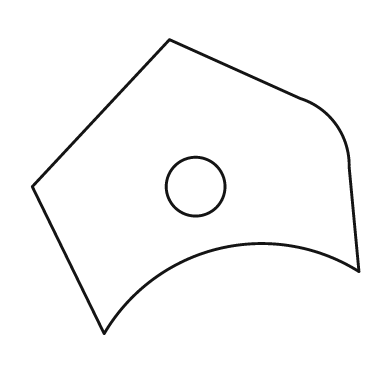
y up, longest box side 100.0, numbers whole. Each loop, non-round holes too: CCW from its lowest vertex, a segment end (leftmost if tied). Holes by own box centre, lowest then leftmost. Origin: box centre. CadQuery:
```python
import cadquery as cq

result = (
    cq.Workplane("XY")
    .moveTo(-28.0, -45.0)
    .threePointArc((7.0, -19.0), (50.0, -26.0))
    .lineTo(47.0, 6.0)
    .threePointArc((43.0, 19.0), (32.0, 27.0))
    .lineTo(-8.0, 45.0)
    .lineTo(-50.0, 0.0)
    .close()
    .moveTo(0.0, 0.0)
    .circle(9.0)
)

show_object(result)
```